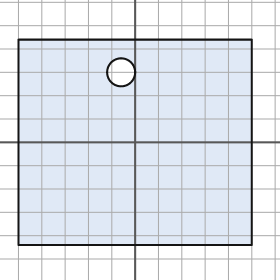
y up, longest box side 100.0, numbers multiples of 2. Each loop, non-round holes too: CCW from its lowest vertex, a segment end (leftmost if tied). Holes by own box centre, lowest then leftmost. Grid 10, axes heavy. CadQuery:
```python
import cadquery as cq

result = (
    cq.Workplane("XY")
    .moveTo(-50.0, -44.0)
    .lineTo(50.0, -44.0)
    .lineTo(50.0, 44.0)
    .lineTo(-50.0, 44.0)
    .close()
    .moveTo(-6.0, 30.0)
    .circle(6.0)
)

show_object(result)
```